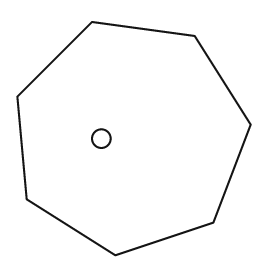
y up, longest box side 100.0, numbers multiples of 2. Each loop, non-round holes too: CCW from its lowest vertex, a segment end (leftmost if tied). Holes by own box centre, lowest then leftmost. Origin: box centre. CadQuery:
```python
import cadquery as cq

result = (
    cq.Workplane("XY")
    .moveTo(-8.0, -50.0)
    .lineTo(34.0, -36.0)
    .lineTo(50.0, 6.0)
    .lineTo(26.0, 44.0)
    .lineTo(-18.0, 50.0)
    .lineTo(-50.0, 18.0)
    .lineTo(-46.0, -26.0)
    .close()
    .moveTo(-14.0, 0.0)
    .circle(4.0)
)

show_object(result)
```